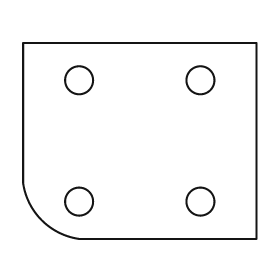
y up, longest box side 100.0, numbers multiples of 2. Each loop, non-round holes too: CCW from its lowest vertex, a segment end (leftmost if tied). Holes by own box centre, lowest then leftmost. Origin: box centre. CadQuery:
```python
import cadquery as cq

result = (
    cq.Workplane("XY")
    .moveTo(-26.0, -42.0)
    .lineTo(50.0, -42.0)
    .lineTo(50.0, 42.0)
    .lineTo(-50.0, 42.0)
    .lineTo(-50.0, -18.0)
    .threePointArc((-42.0, -34.0), (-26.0, -42.0))
    .close()
    .moveTo(-26.0, -26.0)
    .circle(6.0)
    .moveTo(26.0, -26.0)
    .circle(6.0)
    .moveTo(-26.0, 26.0)
    .circle(6.0)
    .moveTo(26.0, 26.0)
    .circle(6.0)
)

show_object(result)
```